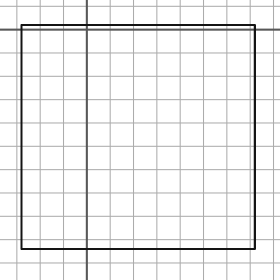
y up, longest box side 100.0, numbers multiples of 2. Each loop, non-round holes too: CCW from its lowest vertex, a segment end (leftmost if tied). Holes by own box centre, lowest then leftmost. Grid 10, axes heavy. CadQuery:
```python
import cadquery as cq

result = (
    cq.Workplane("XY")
    .moveTo(-28.0, -94.0)
    .lineTo(72.0, -94.0)
    .lineTo(72.0, 2.0)
    .lineTo(-28.0, 2.0)
    .close()
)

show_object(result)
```